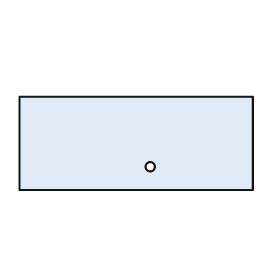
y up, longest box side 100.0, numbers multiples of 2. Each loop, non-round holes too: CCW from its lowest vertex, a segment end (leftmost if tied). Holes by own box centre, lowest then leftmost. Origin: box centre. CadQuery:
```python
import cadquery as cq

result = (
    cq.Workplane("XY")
    .moveTo(-50.0, -20.0)
    .lineTo(50.0, -20.0)
    .lineTo(50.0, 20.0)
    .lineTo(-50.0, 20.0)
    .close()
    .moveTo(6.0, -10.0)
    .circle(2.0)
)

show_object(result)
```